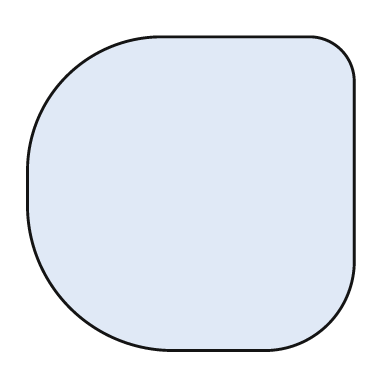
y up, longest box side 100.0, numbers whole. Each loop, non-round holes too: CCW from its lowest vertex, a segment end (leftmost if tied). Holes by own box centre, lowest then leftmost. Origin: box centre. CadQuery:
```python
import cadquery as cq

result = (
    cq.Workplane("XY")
    .moveTo(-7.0, -48.0)
    .lineTo(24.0, -48.0)
    .threePointArc((42.0, -40.0), (50.0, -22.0))
    .lineTo(50.0, 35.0)
    .threePointArc((46.0, 44.0), (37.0, 48.0))
    .lineTo(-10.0, 48.0)
    .threePointArc((-38.0, 36.0), (-50.0, 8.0))
    .lineTo(-50.0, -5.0)
    .threePointArc((-37.0, -35.0), (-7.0, -48.0))
    .close()
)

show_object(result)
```